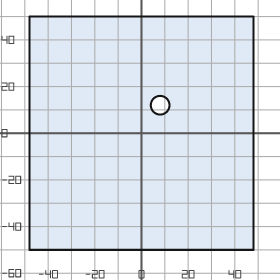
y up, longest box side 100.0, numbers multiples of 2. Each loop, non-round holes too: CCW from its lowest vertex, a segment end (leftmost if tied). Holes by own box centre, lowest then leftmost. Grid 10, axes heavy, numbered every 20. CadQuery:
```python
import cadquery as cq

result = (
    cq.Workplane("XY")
    .moveTo(-48.0, -50.0)
    .lineTo(48.0, -50.0)
    .lineTo(48.0, 50.0)
    .lineTo(-48.0, 50.0)
    .close()
    .moveTo(8.0, 12.0)
    .circle(4.0)
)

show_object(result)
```